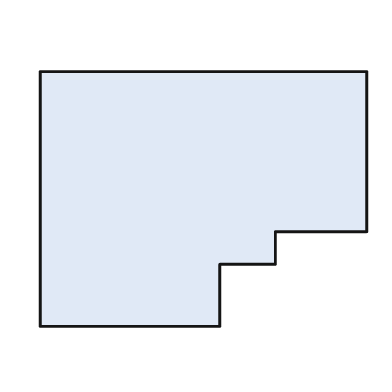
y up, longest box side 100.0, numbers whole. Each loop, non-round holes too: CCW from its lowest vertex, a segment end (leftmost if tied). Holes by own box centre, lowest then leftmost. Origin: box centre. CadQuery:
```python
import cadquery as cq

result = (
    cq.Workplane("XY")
    .moveTo(-50.0, -39.0)
    .lineTo(5.0, -39.0)
    .lineTo(5.0, -20.0)
    .lineTo(22.0, -20.0)
    .lineTo(22.0, -10.0)
    .lineTo(50.0, -10.0)
    .lineTo(50.0, 39.0)
    .lineTo(-50.0, 39.0)
    .close()
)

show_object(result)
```